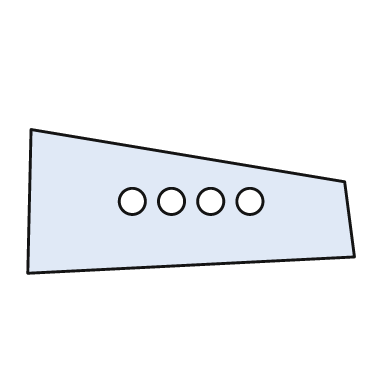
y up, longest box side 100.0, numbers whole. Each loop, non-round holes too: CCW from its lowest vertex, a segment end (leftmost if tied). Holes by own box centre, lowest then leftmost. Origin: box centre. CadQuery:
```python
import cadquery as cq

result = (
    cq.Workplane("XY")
    .moveTo(-50.0, -22.0)
    .lineTo(50.0, -17.0)
    .lineTo(47.0, 6.0)
    .lineTo(-49.0, 22.0)
    .close()
    .moveTo(-18.0, 0.0)
    .circle(4.0)
    .moveTo(-6.0, 0.0)
    .circle(4.0)
    .moveTo(6.0, 0.0)
    .circle(4.0)
    .moveTo(18.0, 0.0)
    .circle(4.0)
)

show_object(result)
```